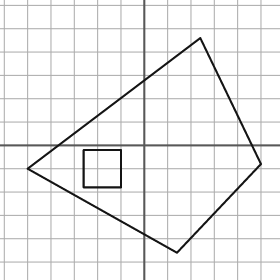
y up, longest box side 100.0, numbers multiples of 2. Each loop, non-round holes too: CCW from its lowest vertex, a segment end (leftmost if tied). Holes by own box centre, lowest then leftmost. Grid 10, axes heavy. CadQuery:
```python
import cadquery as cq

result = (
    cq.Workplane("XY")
    .moveTo(14.0, -46.0)
    .lineTo(50.0, -8.0)
    .lineTo(24.0, 46.0)
    .lineTo(-50.0, -10.0)
    .close()
    .moveTo(-26.0, -18.0)
    .lineTo(-10.0, -18.0)
    .lineTo(-10.0, -2.0)
    .lineTo(-26.0, -2.0)
    .close()
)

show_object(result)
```